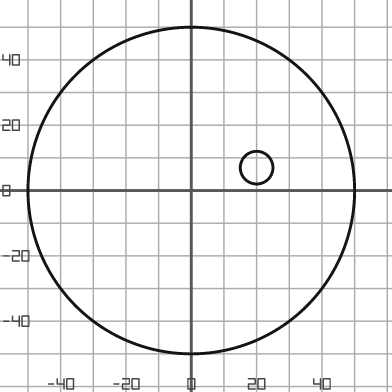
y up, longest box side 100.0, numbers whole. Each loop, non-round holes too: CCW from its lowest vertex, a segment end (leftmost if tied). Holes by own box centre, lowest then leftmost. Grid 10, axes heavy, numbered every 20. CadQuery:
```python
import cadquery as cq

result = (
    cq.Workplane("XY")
    .moveTo(0.0, 0.0)
    .circle(50.0)
    .moveTo(20.0, 7.0)
    .circle(5.0)
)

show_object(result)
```